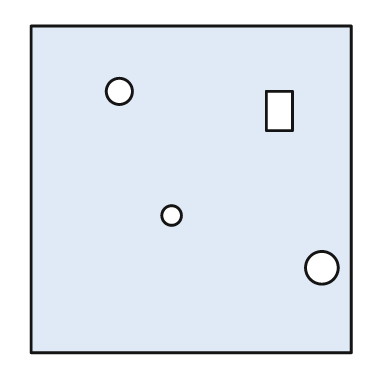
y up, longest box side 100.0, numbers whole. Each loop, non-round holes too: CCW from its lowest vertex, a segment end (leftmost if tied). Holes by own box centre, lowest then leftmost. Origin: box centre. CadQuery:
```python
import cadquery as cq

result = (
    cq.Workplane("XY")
    .moveTo(-49.0, -50.0)
    .lineTo(49.0, -50.0)
    .lineTo(49.0, 50.0)
    .lineTo(-49.0, 50.0)
    .close()
    .moveTo(40.0, -24.0)
    .circle(5.0)
    .moveTo(-6.0, -8.0)
    .circle(3.0)
    .moveTo(23.0, 18.0)
    .lineTo(31.0, 18.0)
    .lineTo(31.0, 30.0)
    .lineTo(23.0, 30.0)
    .close()
    .moveTo(-22.0, 30.0)
    .circle(4.0)
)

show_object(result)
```